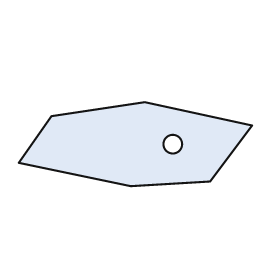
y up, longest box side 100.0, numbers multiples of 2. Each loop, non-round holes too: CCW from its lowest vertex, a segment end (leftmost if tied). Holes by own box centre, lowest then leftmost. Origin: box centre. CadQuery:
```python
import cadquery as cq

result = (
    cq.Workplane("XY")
    .moveTo(-2.0, -18.0)
    .lineTo(32.0, -16.0)
    .lineTo(50.0, 8.0)
    .lineTo(4.0, 18.0)
    .lineTo(-36.0, 12.0)
    .lineTo(-50.0, -8.0)
    .close()
    .moveTo(16.0, 0.0)
    .circle(4.0)
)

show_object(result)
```